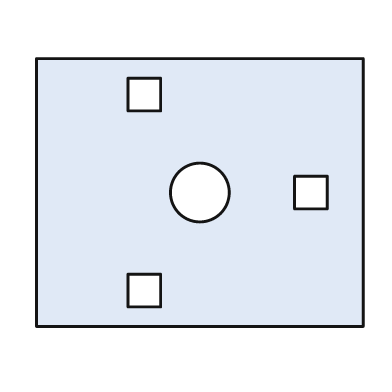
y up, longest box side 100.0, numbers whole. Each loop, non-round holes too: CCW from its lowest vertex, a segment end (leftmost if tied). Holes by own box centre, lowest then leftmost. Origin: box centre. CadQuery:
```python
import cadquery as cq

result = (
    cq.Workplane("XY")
    .moveTo(-50.0, -41.0)
    .lineTo(50.0, -41.0)
    .lineTo(50.0, 41.0)
    .lineTo(-50.0, 41.0)
    .close()
    .moveTo(-22.0, -35.0)
    .lineTo(-12.0, -35.0)
    .lineTo(-12.0, -25.0)
    .lineTo(-22.0, -25.0)
    .close()
    .moveTo(0.0, 0.0)
    .circle(9.0)
    .moveTo(29.0, -5.0)
    .lineTo(39.0, -5.0)
    .lineTo(39.0, 5.0)
    .lineTo(29.0, 5.0)
    .close()
    .moveTo(-22.0, 25.0)
    .lineTo(-12.0, 25.0)
    .lineTo(-12.0, 35.0)
    .lineTo(-22.0, 35.0)
    .close()
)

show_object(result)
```